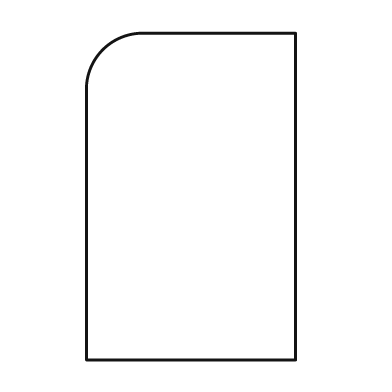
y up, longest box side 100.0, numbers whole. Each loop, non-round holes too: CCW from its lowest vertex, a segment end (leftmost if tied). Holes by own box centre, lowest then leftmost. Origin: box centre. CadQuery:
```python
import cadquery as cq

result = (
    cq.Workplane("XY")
    .moveTo(-32.0, -50.0)
    .lineTo(32.0, -50.0)
    .lineTo(32.0, 50.0)
    .lineTo(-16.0, 50.0)
    .threePointArc((-27.0, 45.0), (-32.0, 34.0))
    .close()
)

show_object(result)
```